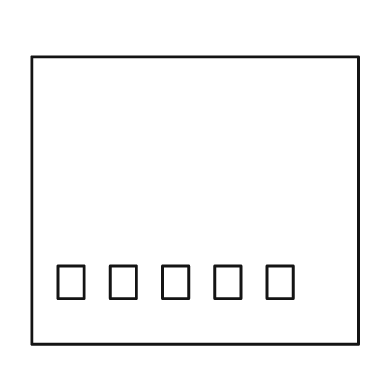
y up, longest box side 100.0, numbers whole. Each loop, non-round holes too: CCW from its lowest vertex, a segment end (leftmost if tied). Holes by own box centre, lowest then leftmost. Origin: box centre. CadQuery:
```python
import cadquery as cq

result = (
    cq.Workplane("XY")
    .moveTo(-50.0, -44.0)
    .lineTo(50.0, -44.0)
    .lineTo(50.0, 44.0)
    .lineTo(-50.0, 44.0)
    .close()
    .moveTo(-42.0, -30.0)
    .lineTo(-34.0, -30.0)
    .lineTo(-34.0, -20.0)
    .lineTo(-42.0, -20.0)
    .close()
    .moveTo(-26.0, -30.0)
    .lineTo(-18.0, -30.0)
    .lineTo(-18.0, -20.0)
    .lineTo(-26.0, -20.0)
    .close()
    .moveTo(-10.0, -30.0)
    .lineTo(-2.0, -30.0)
    .lineTo(-2.0, -20.0)
    .lineTo(-10.0, -20.0)
    .close()
    .moveTo(6.0, -30.0)
    .lineTo(14.0, -30.0)
    .lineTo(14.0, -20.0)
    .lineTo(6.0, -20.0)
    .close()
    .moveTo(22.0, -30.0)
    .lineTo(30.0, -30.0)
    .lineTo(30.0, -20.0)
    .lineTo(22.0, -20.0)
    .close()
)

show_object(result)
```